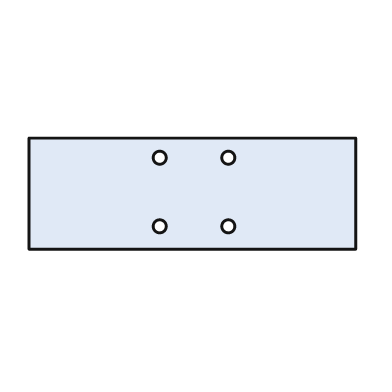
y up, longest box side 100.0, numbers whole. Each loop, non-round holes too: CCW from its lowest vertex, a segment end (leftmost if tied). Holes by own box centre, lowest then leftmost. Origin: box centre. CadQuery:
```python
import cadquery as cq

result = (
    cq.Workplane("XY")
    .moveTo(-50.0, -17.0)
    .lineTo(50.0, -17.0)
    .lineTo(50.0, 17.0)
    .lineTo(-50.0, 17.0)
    .close()
    .moveTo(-10.0, -10.0)
    .circle(2.0)
    .moveTo(11.0, -10.0)
    .circle(2.0)
    .moveTo(-10.0, 11.0)
    .circle(2.0)
    .moveTo(11.0, 11.0)
    .circle(2.0)
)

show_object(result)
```